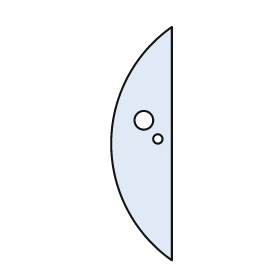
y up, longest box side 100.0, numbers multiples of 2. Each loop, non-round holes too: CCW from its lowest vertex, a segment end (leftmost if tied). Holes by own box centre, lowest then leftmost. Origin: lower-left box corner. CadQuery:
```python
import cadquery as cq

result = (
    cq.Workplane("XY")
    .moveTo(26.0, 0.0)
    .lineTo(26.0, 100.0)
    .threePointArc((0.0, 50.0), (26.0, 0.0))
    .close()
    .moveTo(20.0, 52.0)
    .circle(2.0)
    .moveTo(14.0, 60.0)
    .circle(4.0)
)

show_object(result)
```